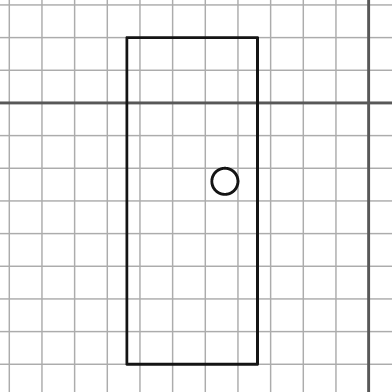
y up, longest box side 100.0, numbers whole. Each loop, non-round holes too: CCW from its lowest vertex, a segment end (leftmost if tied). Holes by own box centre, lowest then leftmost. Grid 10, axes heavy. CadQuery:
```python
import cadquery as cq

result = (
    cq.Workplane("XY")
    .moveTo(-74.0, -80.0)
    .lineTo(-34.0, -80.0)
    .lineTo(-34.0, 20.0)
    .lineTo(-74.0, 20.0)
    .close()
    .moveTo(-44.0, -24.0)
    .circle(4.0)
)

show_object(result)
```